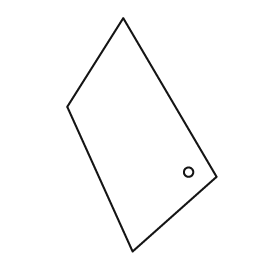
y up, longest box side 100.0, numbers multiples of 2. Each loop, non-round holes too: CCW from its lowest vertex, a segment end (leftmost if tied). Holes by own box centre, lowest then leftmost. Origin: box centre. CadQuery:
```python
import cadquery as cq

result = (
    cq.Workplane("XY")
    .moveTo(-4.0, -50.0)
    .lineTo(32.0, -18.0)
    .lineTo(-8.0, 50.0)
    .lineTo(-32.0, 12.0)
    .close()
    .moveTo(20.0, -16.0)
    .circle(2.0)
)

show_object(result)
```